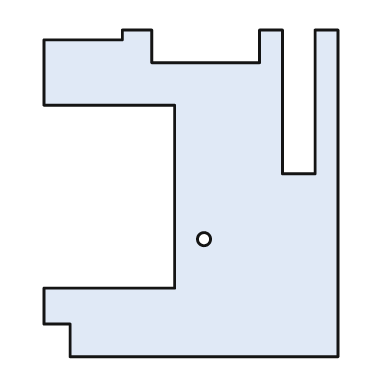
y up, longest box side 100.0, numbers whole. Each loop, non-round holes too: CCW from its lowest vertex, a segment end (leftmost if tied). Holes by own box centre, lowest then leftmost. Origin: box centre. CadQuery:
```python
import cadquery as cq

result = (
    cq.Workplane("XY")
    .moveTo(-37.0, -50.0)
    .lineTo(45.0, -50.0)
    .lineTo(45.0, 50.0)
    .lineTo(38.0, 50.0)
    .lineTo(38.0, 6.0)
    .lineTo(28.0, 6.0)
    .lineTo(28.0, 50.0)
    .lineTo(21.0, 50.0)
    .lineTo(21.0, 40.0)
    .lineTo(-12.0, 40.0)
    .lineTo(-12.0, 50.0)
    .lineTo(-21.0, 50.0)
    .lineTo(-21.0, 47.0)
    .lineTo(-45.0, 47.0)
    .lineTo(-45.0, 27.0)
    .lineTo(-5.0, 27.0)
    .lineTo(-5.0, -29.0)
    .lineTo(-45.0, -29.0)
    .lineTo(-45.0, -40.0)
    .lineTo(-37.0, -40.0)
    .close()
    .moveTo(4.0, -14.0)
    .circle(2.0)
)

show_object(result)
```